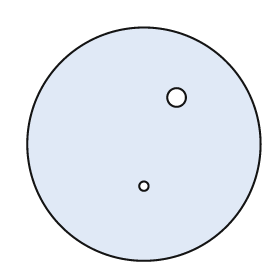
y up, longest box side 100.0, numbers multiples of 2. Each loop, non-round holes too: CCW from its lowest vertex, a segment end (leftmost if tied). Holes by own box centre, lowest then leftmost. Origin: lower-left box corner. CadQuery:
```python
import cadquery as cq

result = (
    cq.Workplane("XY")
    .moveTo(50.0, 50.0)
    .circle(50.0)
    .moveTo(50.0, 32.0)
    .circle(2.0)
    .moveTo(64.0, 70.0)
    .circle(4.0)
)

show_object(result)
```